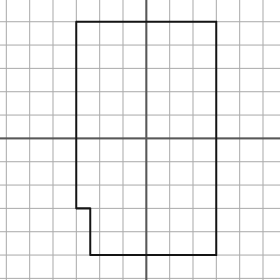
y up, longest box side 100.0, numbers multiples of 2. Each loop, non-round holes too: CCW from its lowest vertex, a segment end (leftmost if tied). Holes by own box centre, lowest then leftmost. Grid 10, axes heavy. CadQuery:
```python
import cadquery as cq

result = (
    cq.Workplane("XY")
    .moveTo(-24.0, -50.0)
    .lineTo(30.0, -50.0)
    .lineTo(30.0, 50.0)
    .lineTo(-30.0, 50.0)
    .lineTo(-30.0, -30.0)
    .lineTo(-24.0, -30.0)
    .close()
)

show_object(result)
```